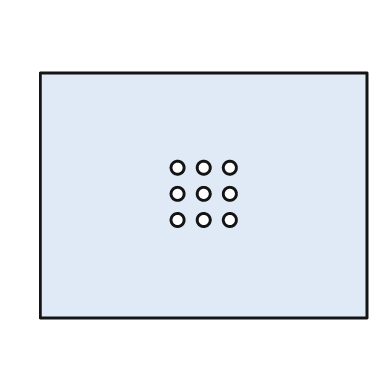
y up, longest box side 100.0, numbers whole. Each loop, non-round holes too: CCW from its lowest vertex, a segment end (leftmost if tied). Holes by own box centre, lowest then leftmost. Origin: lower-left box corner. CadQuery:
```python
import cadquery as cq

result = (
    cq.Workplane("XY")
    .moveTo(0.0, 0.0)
    .lineTo(100.0, 0.0)
    .lineTo(100.0, 75.0)
    .lineTo(0.0, 75.0)
    .close()
    .moveTo(42.0, 30.0)
    .circle(2.0)
    .moveTo(50.0, 30.0)
    .circle(2.0)
    .moveTo(58.0, 30.0)
    .circle(2.0)
    .moveTo(42.0, 38.0)
    .circle(2.0)
    .moveTo(50.0, 38.0)
    .circle(2.0)
    .moveTo(58.0, 38.0)
    .circle(2.0)
    .moveTo(42.0, 46.0)
    .circle(2.0)
    .moveTo(50.0, 46.0)
    .circle(2.0)
    .moveTo(58.0, 46.0)
    .circle(2.0)
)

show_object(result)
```